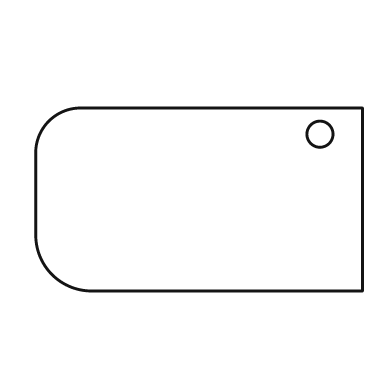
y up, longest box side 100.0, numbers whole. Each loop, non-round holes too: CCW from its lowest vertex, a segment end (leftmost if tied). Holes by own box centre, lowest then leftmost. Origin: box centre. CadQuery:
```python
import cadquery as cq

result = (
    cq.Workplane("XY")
    .moveTo(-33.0, -28.0)
    .lineTo(50.0, -28.0)
    .lineTo(50.0, 28.0)
    .lineTo(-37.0, 28.0)
    .threePointArc((-46.0, 24.0), (-50.0, 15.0))
    .lineTo(-50.0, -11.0)
    .threePointArc((-45.0, -23.0), (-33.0, -28.0))
    .close()
    .moveTo(37.0, 20.0)
    .circle(4.0)
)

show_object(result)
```